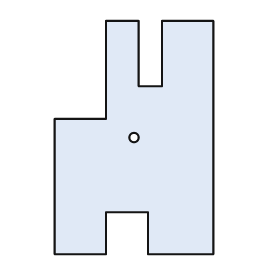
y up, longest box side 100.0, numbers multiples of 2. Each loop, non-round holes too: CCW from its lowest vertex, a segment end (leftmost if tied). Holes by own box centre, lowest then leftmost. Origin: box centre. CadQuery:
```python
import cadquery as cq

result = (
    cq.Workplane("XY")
    .moveTo(-34.0, -50.0)
    .lineTo(-12.0, -50.0)
    .lineTo(-12.0, -32.0)
    .lineTo(6.0, -32.0)
    .lineTo(6.0, -50.0)
    .lineTo(34.0, -50.0)
    .lineTo(34.0, 50.0)
    .lineTo(12.0, 50.0)
    .lineTo(12.0, 22.0)
    .lineTo(2.0, 22.0)
    .lineTo(2.0, 50.0)
    .lineTo(-12.0, 50.0)
    .lineTo(-12.0, 8.0)
    .lineTo(-34.0, 8.0)
    .close()
    .moveTo(0.0, 0.0)
    .circle(2.0)
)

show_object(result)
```